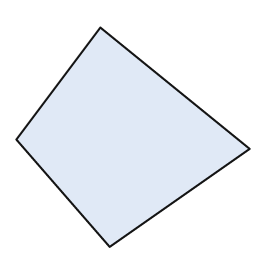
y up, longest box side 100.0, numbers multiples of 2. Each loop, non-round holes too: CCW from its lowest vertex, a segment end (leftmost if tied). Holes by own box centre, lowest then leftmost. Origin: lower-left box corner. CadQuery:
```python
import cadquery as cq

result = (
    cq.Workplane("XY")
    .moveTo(40.0, 0.0)
    .lineTo(100.0, 42.0)
    .lineTo(36.0, 94.0)
    .lineTo(0.0, 46.0)
    .close()
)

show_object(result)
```